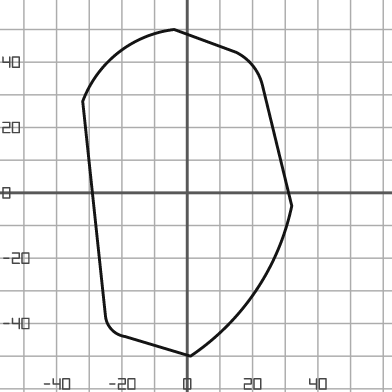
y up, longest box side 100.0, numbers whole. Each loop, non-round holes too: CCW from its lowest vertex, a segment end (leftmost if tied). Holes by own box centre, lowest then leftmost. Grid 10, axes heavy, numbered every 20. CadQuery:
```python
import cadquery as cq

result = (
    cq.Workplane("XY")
    .moveTo(1.0, -50.0)
    .threePointArc((21.0, -30.0), (32.0, -4.0))
    .lineTo(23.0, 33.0)
    .threePointArc((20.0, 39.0), (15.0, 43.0))
    .lineTo(-4.0, 50.0)
    .threePointArc((-21.0, 43.0), (-32.0, 28.0))
    .lineTo(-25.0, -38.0)
    .threePointArc((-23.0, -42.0), (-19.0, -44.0))
    .close()
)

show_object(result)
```